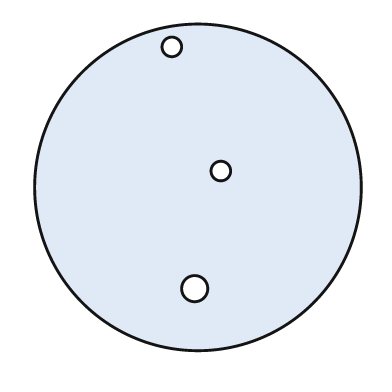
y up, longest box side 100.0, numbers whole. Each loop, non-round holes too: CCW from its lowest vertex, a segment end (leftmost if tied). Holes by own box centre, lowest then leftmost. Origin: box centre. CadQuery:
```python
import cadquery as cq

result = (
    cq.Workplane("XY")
    .moveTo(0.0, 0.0)
    .circle(50.0)
    .moveTo(-1.0, -31.0)
    .circle(4.0)
    .moveTo(7.0, 5.0)
    .circle(3.0)
    .moveTo(-8.0, 43.0)
    .circle(3.0)
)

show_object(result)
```